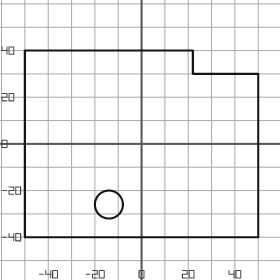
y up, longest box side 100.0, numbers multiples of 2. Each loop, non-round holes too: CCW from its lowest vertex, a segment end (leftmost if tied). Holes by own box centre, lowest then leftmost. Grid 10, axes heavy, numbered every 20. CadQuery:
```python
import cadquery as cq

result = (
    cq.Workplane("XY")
    .moveTo(-50.0, -40.0)
    .lineTo(50.0, -40.0)
    .lineTo(50.0, 30.0)
    .lineTo(22.0, 30.0)
    .lineTo(22.0, 40.0)
    .lineTo(-50.0, 40.0)
    .close()
    .moveTo(-14.0, -26.0)
    .circle(6.0)
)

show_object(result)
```